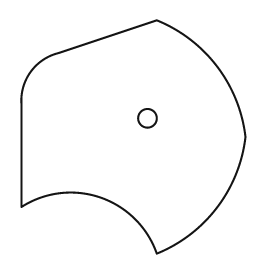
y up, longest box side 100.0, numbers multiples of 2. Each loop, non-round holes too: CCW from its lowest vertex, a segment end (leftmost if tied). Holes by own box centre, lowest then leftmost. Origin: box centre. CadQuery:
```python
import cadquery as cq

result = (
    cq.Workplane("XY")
    .moveTo(10.0, -50.0)
    .threePointArc((36.0, -30.0), (48.0, 0.0))
    .threePointArc((36.0, 30.0), (10.0, 50.0))
    .lineTo(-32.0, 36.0)
    .threePointArc((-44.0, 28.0), (-48.0, 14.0))
    .lineTo(-48.0, -30.0)
    .threePointArc((-14.0, -26.0), (10.0, -50.0))
    .close()
    .moveTo(6.0, 8.0)
    .circle(4.0)
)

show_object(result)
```